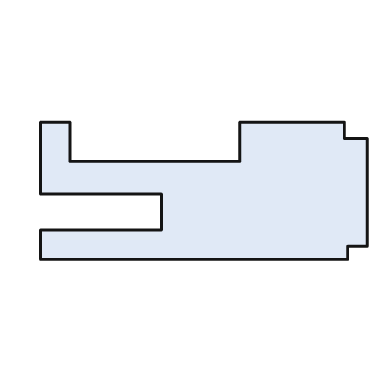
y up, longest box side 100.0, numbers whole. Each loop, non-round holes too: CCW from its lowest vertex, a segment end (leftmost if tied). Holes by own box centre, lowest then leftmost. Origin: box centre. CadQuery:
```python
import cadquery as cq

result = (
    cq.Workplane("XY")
    .moveTo(-50.0, -21.0)
    .lineTo(44.0, -21.0)
    .lineTo(44.0, -17.0)
    .lineTo(50.0, -17.0)
    .lineTo(50.0, 16.0)
    .lineTo(43.0, 16.0)
    .lineTo(43.0, 21.0)
    .lineTo(11.0, 21.0)
    .lineTo(11.0, 9.0)
    .lineTo(-41.0, 9.0)
    .lineTo(-41.0, 21.0)
    .lineTo(-50.0, 21.0)
    .lineTo(-50.0, -1.0)
    .lineTo(-13.0, -1.0)
    .lineTo(-13.0, -12.0)
    .lineTo(-50.0, -12.0)
    .close()
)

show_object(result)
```